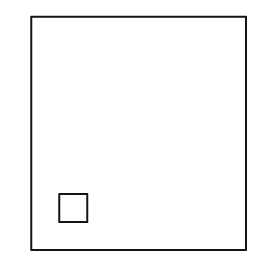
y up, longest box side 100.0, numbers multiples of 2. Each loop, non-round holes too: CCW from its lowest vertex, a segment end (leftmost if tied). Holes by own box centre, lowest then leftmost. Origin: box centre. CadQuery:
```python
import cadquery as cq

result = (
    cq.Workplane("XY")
    .moveTo(-46.0, -50.0)
    .lineTo(46.0, -50.0)
    .lineTo(46.0, 50.0)
    .lineTo(-46.0, 50.0)
    .close()
    .moveTo(-34.0, -38.0)
    .lineTo(-22.0, -38.0)
    .lineTo(-22.0, -26.0)
    .lineTo(-34.0, -26.0)
    .close()
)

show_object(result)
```